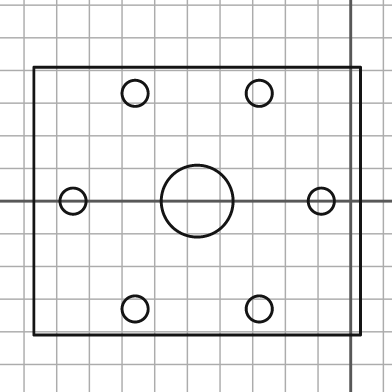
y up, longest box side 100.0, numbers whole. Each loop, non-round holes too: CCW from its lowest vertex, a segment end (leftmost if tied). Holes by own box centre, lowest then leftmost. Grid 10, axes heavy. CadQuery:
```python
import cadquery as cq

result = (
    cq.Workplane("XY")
    .moveTo(-97.0, -41.0)
    .lineTo(3.0, -41.0)
    .lineTo(3.0, 41.0)
    .lineTo(-97.0, 41.0)
    .close()
    .moveTo(-66.0, -33.0)
    .circle(4.0)
    .moveTo(-28.0, -33.0)
    .circle(4.0)
    .moveTo(-85.0, 0.0)
    .circle(4.0)
    .moveTo(-47.0, 0.0)
    .circle(11.0)
    .moveTo(-9.0, 0.0)
    .circle(4.0)
    .moveTo(-66.0, 33.0)
    .circle(4.0)
    .moveTo(-28.0, 33.0)
    .circle(4.0)
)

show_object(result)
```